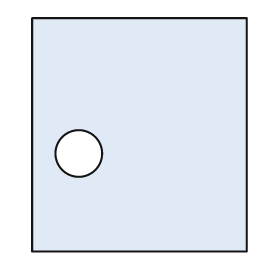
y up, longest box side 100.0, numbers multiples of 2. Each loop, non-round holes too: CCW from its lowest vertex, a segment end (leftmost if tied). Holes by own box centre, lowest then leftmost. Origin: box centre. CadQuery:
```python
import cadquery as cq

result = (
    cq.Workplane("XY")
    .moveTo(-46.0, -50.0)
    .lineTo(46.0, -50.0)
    .lineTo(46.0, 50.0)
    .lineTo(-46.0, 50.0)
    .close()
    .moveTo(-26.0, -8.0)
    .circle(10.0)
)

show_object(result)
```